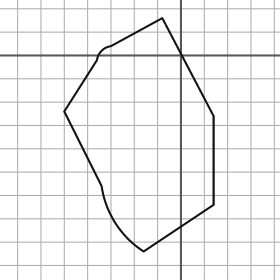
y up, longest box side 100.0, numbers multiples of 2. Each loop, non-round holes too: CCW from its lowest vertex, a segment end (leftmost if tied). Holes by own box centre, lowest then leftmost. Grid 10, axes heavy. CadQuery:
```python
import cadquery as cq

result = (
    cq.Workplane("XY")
    .moveTo(-16.0, -84.0)
    .lineTo(14.0, -64.0)
    .lineTo(14.0, -26.0)
    .lineTo(-8.0, 16.0)
    .lineTo(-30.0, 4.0)
    .threePointArc((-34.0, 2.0), (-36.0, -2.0))
    .lineTo(-50.0, -24.0)
    .lineTo(-34.0, -56.0)
    .threePointArc((-28.0, -72.0), (-16.0, -84.0))
    .close()
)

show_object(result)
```